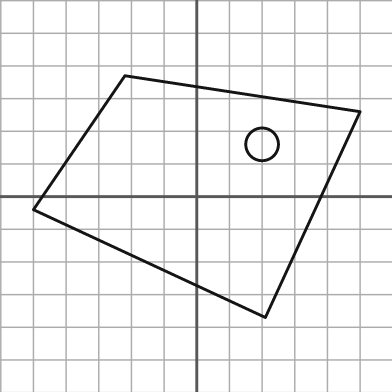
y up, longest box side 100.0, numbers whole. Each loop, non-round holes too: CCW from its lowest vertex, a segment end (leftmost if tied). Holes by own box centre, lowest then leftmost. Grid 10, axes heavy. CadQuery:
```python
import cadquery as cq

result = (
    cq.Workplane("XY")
    .moveTo(21.0, -37.0)
    .lineTo(50.0, 26.0)
    .lineTo(-22.0, 37.0)
    .lineTo(-50.0, -4.0)
    .close()
    .moveTo(20.0, 16.0)
    .circle(5.0)
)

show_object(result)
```